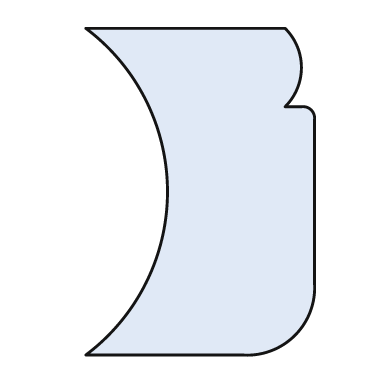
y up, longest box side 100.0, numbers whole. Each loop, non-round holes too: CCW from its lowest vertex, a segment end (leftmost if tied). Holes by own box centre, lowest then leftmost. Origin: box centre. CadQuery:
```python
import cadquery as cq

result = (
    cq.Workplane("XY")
    .moveTo(-35.0, -50.0)
    .lineTo(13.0, -50.0)
    .threePointArc((29.0, -44.0), (35.0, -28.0))
    .lineTo(35.0, 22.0)
    .threePointArc((34.0, 25.0), (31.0, 26.0))
    .lineTo(26.0, 26.0)
    .threePointArc((31.0, 38.0), (26.0, 50.0))
    .lineTo(-35.0, 50.0)
    .threePointArc((-10.0, 0.0), (-35.0, -50.0))
    .close()
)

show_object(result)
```